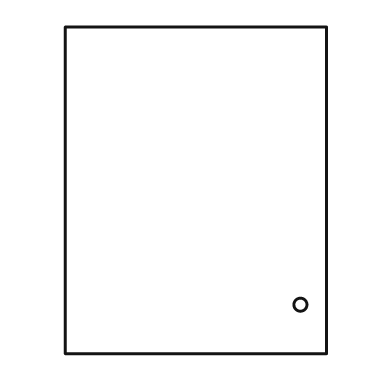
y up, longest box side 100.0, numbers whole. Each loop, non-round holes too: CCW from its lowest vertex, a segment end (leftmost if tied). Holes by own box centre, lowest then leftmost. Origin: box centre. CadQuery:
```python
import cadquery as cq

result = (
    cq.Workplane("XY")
    .moveTo(-40.0, -50.0)
    .lineTo(40.0, -50.0)
    .lineTo(40.0, 50.0)
    .lineTo(-40.0, 50.0)
    .close()
    .moveTo(32.0, -35.0)
    .circle(2.0)
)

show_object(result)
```